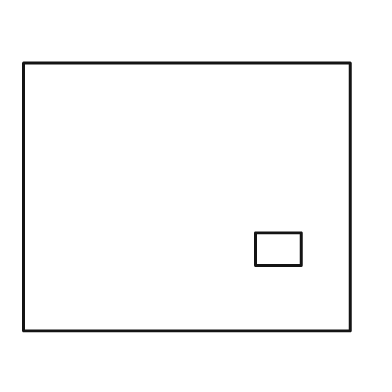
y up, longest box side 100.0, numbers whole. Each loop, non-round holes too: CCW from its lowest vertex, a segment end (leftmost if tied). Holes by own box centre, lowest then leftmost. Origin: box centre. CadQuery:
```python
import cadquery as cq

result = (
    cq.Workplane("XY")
    .moveTo(-50.0, -41.0)
    .lineTo(50.0, -41.0)
    .lineTo(50.0, 41.0)
    .lineTo(-50.0, 41.0)
    .close()
    .moveTo(21.0, -21.0)
    .lineTo(35.0, -21.0)
    .lineTo(35.0, -11.0)
    .lineTo(21.0, -11.0)
    .close()
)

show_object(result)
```